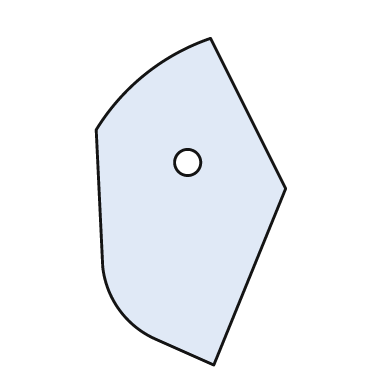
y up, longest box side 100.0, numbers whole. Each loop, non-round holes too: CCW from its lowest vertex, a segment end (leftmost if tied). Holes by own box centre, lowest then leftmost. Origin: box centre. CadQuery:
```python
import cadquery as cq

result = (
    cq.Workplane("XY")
    .moveTo(7.0, -50.0)
    .lineTo(29.0, 4.0)
    .lineTo(6.0, 50.0)
    .threePointArc((-14.0, 39.0), (-29.0, 22.0))
    .lineTo(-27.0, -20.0)
    .threePointArc((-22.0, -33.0), (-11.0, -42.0))
    .close()
    .moveTo(-1.0, 12.0)
    .circle(4.0)
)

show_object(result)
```